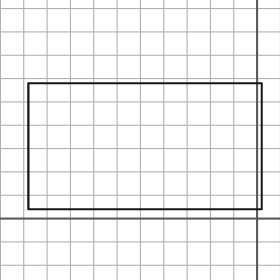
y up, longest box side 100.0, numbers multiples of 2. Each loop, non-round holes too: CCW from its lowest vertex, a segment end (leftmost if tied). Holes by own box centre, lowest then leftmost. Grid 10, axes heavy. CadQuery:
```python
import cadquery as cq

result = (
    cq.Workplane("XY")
    .moveTo(-98.0, 4.0)
    .lineTo(2.0, 4.0)
    .lineTo(2.0, 58.0)
    .lineTo(-98.0, 58.0)
    .close()
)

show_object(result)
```